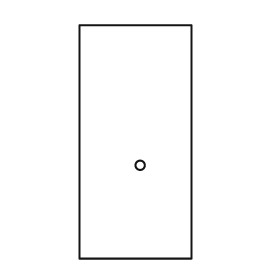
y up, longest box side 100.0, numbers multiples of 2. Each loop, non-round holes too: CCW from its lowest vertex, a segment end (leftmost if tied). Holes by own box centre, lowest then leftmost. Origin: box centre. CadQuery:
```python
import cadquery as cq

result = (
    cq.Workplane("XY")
    .moveTo(-24.0, -50.0)
    .lineTo(24.0, -50.0)
    .lineTo(24.0, 50.0)
    .lineTo(-24.0, 50.0)
    .close()
    .moveTo(2.0, -10.0)
    .circle(2.0)
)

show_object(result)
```